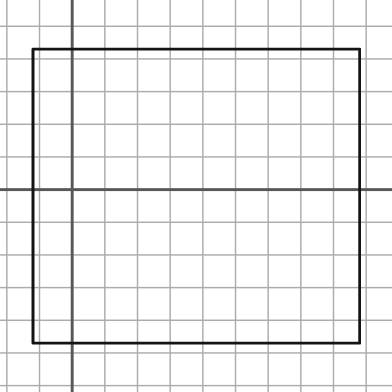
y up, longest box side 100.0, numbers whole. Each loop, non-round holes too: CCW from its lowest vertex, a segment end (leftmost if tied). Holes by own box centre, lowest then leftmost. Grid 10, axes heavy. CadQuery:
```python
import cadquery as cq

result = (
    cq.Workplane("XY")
    .moveTo(-12.0, -47.0)
    .lineTo(88.0, -47.0)
    .lineTo(88.0, 43.0)
    .lineTo(-12.0, 43.0)
    .close()
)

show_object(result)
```